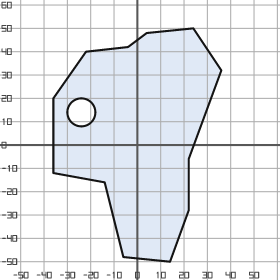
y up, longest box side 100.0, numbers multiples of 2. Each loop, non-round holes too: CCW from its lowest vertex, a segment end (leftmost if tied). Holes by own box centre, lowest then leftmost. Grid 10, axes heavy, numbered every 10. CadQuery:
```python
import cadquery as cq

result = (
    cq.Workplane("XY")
    .moveTo(14.0, -50.0)
    .lineTo(22.0, -28.0)
    .lineTo(22.0, -6.0)
    .lineTo(36.0, 32.0)
    .lineTo(24.0, 50.0)
    .lineTo(4.0, 48.0)
    .lineTo(-4.0, 42.0)
    .lineTo(-22.0, 40.0)
    .lineTo(-36.0, 20.0)
    .lineTo(-36.0, -12.0)
    .lineTo(-14.0, -16.0)
    .lineTo(-6.0, -48.0)
    .close()
    .moveTo(-24.0, 14.0)
    .circle(6.0)
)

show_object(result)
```